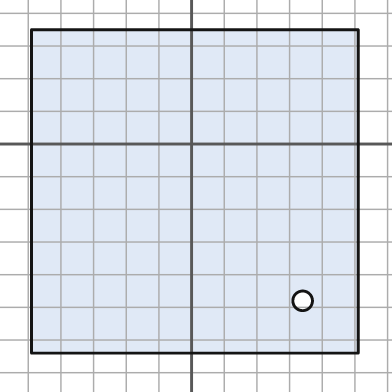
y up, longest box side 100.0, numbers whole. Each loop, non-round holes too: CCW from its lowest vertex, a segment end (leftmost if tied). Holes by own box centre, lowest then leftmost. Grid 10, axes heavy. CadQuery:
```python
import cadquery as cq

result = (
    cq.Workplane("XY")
    .moveTo(-49.0, -64.0)
    .lineTo(51.0, -64.0)
    .lineTo(51.0, 35.0)
    .lineTo(-49.0, 35.0)
    .close()
    .moveTo(34.0, -48.0)
    .circle(3.0)
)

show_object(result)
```